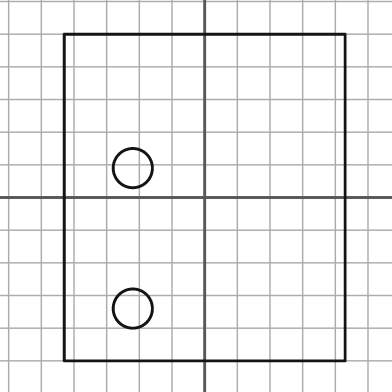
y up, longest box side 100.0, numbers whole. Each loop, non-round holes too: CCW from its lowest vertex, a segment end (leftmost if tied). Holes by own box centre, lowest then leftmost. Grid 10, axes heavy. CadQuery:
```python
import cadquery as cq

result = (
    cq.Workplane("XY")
    .moveTo(-43.0, -50.0)
    .lineTo(43.0, -50.0)
    .lineTo(43.0, 50.0)
    .lineTo(-43.0, 50.0)
    .close()
    .moveTo(-22.0, -34.0)
    .circle(6.0)
    .moveTo(-22.0, 9.0)
    .circle(6.0)
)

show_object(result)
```